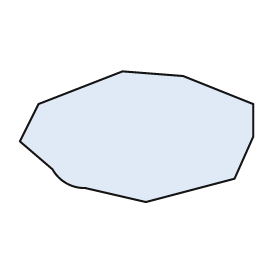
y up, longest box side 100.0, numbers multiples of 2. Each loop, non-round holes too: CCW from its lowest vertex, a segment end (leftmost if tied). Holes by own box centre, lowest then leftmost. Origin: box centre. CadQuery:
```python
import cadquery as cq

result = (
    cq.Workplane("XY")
    .moveTo(4.0, -28.0)
    .lineTo(42.0, -18.0)
    .lineTo(50.0, 0.0)
    .lineTo(50.0, 14.0)
    .lineTo(20.0, 26.0)
    .lineTo(-6.0, 28.0)
    .lineTo(-42.0, 14.0)
    .lineTo(-50.0, -2.0)
    .lineTo(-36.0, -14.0)
    .threePointArc((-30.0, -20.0), (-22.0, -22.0))
    .close()
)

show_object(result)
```